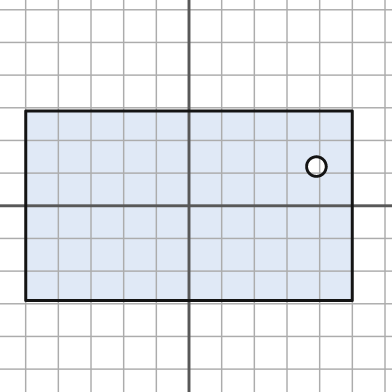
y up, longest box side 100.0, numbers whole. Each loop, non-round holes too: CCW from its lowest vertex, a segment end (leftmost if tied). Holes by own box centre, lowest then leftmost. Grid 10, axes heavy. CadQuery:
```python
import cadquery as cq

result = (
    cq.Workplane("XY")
    .moveTo(-50.0, -29.0)
    .lineTo(50.0, -29.0)
    .lineTo(50.0, 29.0)
    .lineTo(-50.0, 29.0)
    .close()
    .moveTo(39.0, 12.0)
    .circle(3.0)
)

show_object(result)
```